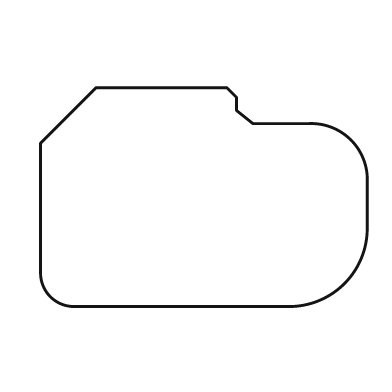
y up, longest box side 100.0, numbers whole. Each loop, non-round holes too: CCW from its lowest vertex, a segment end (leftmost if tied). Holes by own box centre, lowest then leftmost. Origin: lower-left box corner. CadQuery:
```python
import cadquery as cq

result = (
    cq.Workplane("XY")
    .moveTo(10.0, 0.0)
    .lineTo(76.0, 0.0)
    .threePointArc((93.0, 7.0), (100.0, 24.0))
    .lineTo(100.0, 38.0)
    .threePointArc((95.0, 51.0), (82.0, 56.0))
    .lineTo(65.0, 56.0)
    .lineTo(60.0, 60.0)
    .lineTo(60.0, 64.0)
    .lineTo(57.0, 67.0)
    .lineTo(17.0, 67.0)
    .lineTo(0.0, 50.0)
    .lineTo(0.0, 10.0)
    .threePointArc((3.0, 3.0), (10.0, 0.0))
    .close()
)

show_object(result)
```